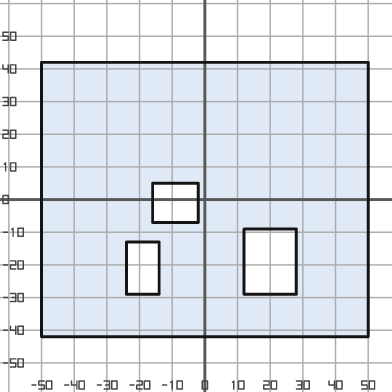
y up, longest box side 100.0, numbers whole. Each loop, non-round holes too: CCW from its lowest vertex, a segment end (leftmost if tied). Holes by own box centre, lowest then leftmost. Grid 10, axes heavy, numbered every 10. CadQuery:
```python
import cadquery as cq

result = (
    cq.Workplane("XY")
    .moveTo(-50.0, -42.0)
    .lineTo(50.0, -42.0)
    .lineTo(50.0, 42.0)
    .lineTo(-50.0, 42.0)
    .close()
    .moveTo(-24.0, -29.0)
    .lineTo(-14.0, -29.0)
    .lineTo(-14.0, -13.0)
    .lineTo(-24.0, -13.0)
    .close()
    .moveTo(12.0, -29.0)
    .lineTo(28.0, -29.0)
    .lineTo(28.0, -9.0)
    .lineTo(12.0, -9.0)
    .close()
    .moveTo(-16.0, -7.0)
    .lineTo(-2.0, -7.0)
    .lineTo(-2.0, 5.0)
    .lineTo(-16.0, 5.0)
    .close()
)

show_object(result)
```